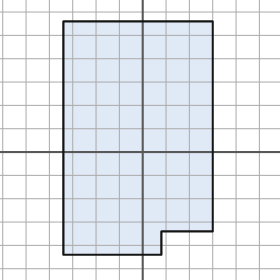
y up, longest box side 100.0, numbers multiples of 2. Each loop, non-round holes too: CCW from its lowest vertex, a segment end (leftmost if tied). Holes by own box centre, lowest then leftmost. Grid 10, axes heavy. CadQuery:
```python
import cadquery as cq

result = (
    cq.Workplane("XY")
    .moveTo(-34.0, -44.0)
    .lineTo(8.0, -44.0)
    .lineTo(8.0, -34.0)
    .lineTo(30.0, -34.0)
    .lineTo(30.0, 56.0)
    .lineTo(-34.0, 56.0)
    .close()
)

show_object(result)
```